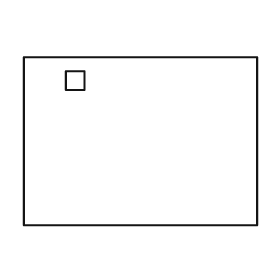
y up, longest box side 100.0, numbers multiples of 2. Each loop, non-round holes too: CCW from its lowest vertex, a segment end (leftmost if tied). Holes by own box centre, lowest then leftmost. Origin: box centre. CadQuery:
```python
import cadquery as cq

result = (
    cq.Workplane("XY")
    .moveTo(-50.0, -36.0)
    .lineTo(50.0, -36.0)
    .lineTo(50.0, 36.0)
    .lineTo(-50.0, 36.0)
    .close()
    .moveTo(-32.0, 22.0)
    .lineTo(-24.0, 22.0)
    .lineTo(-24.0, 30.0)
    .lineTo(-32.0, 30.0)
    .close()
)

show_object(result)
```